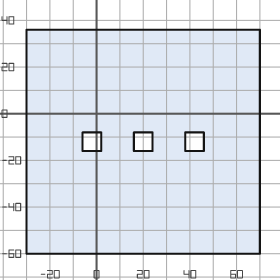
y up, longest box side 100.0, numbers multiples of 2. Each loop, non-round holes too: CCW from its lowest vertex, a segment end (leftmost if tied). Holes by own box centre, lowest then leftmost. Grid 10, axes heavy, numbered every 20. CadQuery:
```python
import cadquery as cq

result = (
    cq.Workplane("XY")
    .moveTo(-30.0, -60.0)
    .lineTo(70.0, -60.0)
    .lineTo(70.0, 36.0)
    .lineTo(-30.0, 36.0)
    .close()
    .moveTo(-6.0, -16.0)
    .lineTo(2.0, -16.0)
    .lineTo(2.0, -8.0)
    .lineTo(-6.0, -8.0)
    .close()
    .moveTo(16.0, -16.0)
    .lineTo(24.0, -16.0)
    .lineTo(24.0, -8.0)
    .lineTo(16.0, -8.0)
    .close()
    .moveTo(38.0, -16.0)
    .lineTo(46.0, -16.0)
    .lineTo(46.0, -8.0)
    .lineTo(38.0, -8.0)
    .close()
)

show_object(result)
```